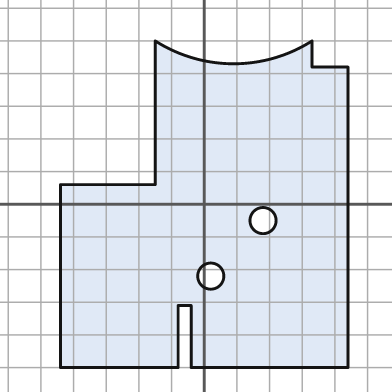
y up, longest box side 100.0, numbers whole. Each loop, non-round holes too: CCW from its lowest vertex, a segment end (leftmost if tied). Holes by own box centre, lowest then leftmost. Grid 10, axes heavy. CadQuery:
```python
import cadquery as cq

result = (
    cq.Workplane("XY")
    .moveTo(-44.0, -50.0)
    .lineTo(-8.0, -50.0)
    .lineTo(-8.0, -31.0)
    .lineTo(-4.0, -31.0)
    .lineTo(-4.0, -50.0)
    .lineTo(44.0, -50.0)
    .lineTo(44.0, 42.0)
    .lineTo(33.0, 42.0)
    .lineTo(33.0, 50.0)
    .threePointArc((9.0, 43.0), (-15.0, 50.0))
    .lineTo(-15.0, 6.0)
    .lineTo(-44.0, 6.0)
    .close()
    .moveTo(2.0, -22.0)
    .circle(4.0)
    .moveTo(18.0, -5.0)
    .circle(4.0)
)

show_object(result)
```